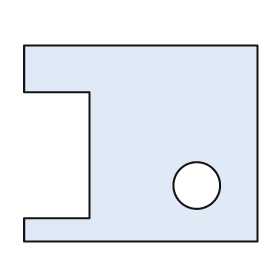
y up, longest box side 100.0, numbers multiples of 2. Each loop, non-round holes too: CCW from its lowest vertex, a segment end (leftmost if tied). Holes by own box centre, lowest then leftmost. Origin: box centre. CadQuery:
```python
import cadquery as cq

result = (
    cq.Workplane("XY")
    .moveTo(-50.0, -42.0)
    .lineTo(50.0, -42.0)
    .lineTo(50.0, 42.0)
    .lineTo(-50.0, 42.0)
    .lineTo(-50.0, 22.0)
    .lineTo(-22.0, 22.0)
    .lineTo(-22.0, -32.0)
    .lineTo(-50.0, -32.0)
    .close()
    .moveTo(24.0, -18.0)
    .circle(10.0)
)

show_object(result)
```